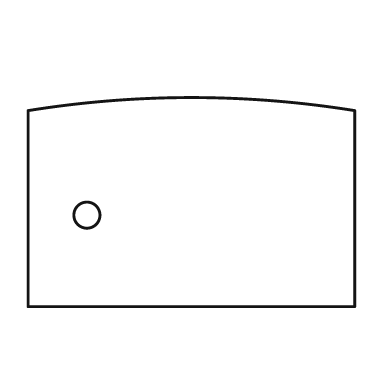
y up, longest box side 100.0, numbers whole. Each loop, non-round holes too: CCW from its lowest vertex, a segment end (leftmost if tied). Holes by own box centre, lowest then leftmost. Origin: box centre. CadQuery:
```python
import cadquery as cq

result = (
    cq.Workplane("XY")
    .moveTo(-50.0, -32.0)
    .lineTo(50.0, -32.0)
    .lineTo(50.0, 28.0)
    .threePointArc((0.0, 32.0), (-50.0, 28.0))
    .close()
    .moveTo(-32.0, -4.0)
    .circle(4.0)
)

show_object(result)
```